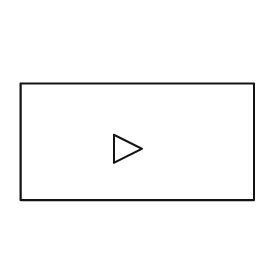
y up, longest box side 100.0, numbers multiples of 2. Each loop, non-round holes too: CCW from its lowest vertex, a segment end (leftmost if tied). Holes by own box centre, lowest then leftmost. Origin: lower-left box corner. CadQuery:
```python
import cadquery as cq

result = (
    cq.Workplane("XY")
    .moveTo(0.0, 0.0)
    .lineTo(100.0, 0.0)
    .lineTo(100.0, 50.0)
    .lineTo(0.0, 50.0)
    .close()
    .moveTo(40.0, 16.0)
    .lineTo(52.0, 22.0)
    .lineTo(40.0, 28.0)
    .close()
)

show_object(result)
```